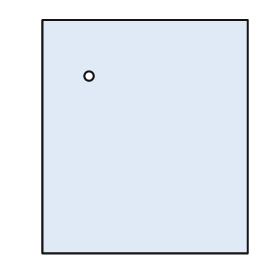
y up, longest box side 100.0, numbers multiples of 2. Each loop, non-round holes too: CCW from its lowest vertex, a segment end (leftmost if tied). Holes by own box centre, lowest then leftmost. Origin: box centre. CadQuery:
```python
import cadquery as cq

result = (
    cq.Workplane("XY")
    .moveTo(-44.0, -50.0)
    .lineTo(44.0, -50.0)
    .lineTo(44.0, 50.0)
    .lineTo(-44.0, 50.0)
    .close()
    .moveTo(-24.0, 26.0)
    .circle(2.0)
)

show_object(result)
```